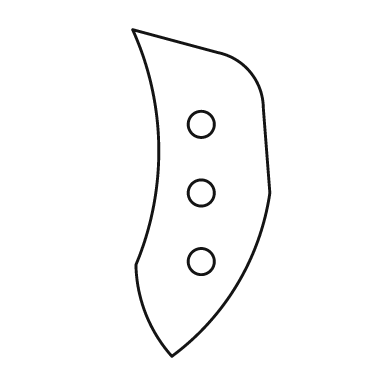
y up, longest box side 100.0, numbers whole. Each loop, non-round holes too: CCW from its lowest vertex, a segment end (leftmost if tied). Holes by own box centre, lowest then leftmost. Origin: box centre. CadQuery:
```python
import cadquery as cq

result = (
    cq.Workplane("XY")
    .moveTo(-9.0, -50.0)
    .threePointArc((11.0, -28.0), (21.0, 0.0))
    .lineTo(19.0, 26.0)
    .threePointArc((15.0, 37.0), (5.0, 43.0))
    .lineTo(-21.0, 50.0)
    .threePointArc((-13.0, 14.0), (-20.0, -22.0))
    .threePointArc((-17.0, -37.0), (-9.0, -50.0))
    .close()
    .moveTo(0.0, -21.0)
    .circle(4.0)
    .moveTo(0.0, 0.0)
    .circle(4.0)
    .moveTo(0.0, 21.0)
    .circle(4.0)
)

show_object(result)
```